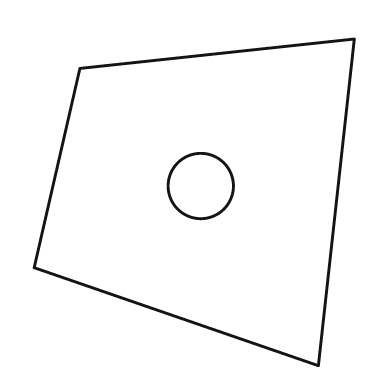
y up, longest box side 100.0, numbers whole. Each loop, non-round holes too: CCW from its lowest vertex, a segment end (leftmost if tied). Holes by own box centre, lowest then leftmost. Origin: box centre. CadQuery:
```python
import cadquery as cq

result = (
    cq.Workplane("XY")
    .moveTo(38.0, -50.0)
    .lineTo(49.0, 50.0)
    .lineTo(-35.0, 41.0)
    .lineTo(-49.0, -20.0)
    .close()
    .moveTo(2.0, 5.0)
    .circle(10.0)
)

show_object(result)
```